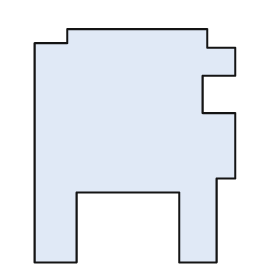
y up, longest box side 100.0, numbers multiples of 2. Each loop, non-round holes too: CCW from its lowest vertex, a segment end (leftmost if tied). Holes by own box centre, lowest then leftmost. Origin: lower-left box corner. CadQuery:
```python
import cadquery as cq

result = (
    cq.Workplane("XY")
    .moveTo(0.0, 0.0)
    .lineTo(18.0, 0.0)
    .lineTo(18.0, 30.0)
    .lineTo(62.0, 30.0)
    .lineTo(62.0, 0.0)
    .lineTo(78.0, 0.0)
    .lineTo(78.0, 36.0)
    .lineTo(86.0, 36.0)
    .lineTo(86.0, 64.0)
    .lineTo(72.0, 64.0)
    .lineTo(72.0, 80.0)
    .lineTo(86.0, 80.0)
    .lineTo(86.0, 92.0)
    .lineTo(74.0, 92.0)
    .lineTo(74.0, 100.0)
    .lineTo(14.0, 100.0)
    .lineTo(14.0, 94.0)
    .lineTo(0.0, 94.0)
    .close()
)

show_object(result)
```